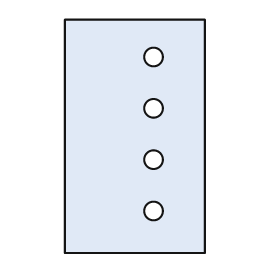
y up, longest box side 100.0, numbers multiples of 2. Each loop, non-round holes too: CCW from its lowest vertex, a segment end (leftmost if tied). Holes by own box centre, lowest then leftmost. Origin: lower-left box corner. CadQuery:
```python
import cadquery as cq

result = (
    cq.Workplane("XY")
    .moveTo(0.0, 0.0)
    .lineTo(60.0, 0.0)
    .lineTo(60.0, 100.0)
    .lineTo(0.0, 100.0)
    .close()
    .moveTo(38.0, 18.0)
    .circle(4.0)
    .moveTo(38.0, 40.0)
    .circle(4.0)
    .moveTo(38.0, 62.0)
    .circle(4.0)
    .moveTo(38.0, 84.0)
    .circle(4.0)
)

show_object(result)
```